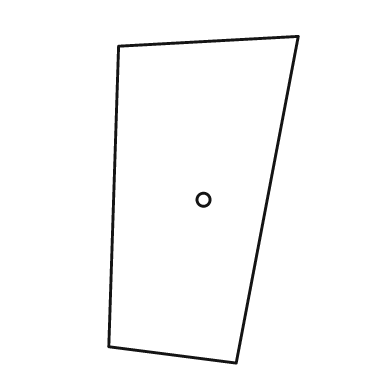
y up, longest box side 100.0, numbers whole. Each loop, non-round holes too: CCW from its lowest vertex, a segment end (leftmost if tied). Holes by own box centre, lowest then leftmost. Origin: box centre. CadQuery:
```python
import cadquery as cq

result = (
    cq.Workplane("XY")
    .moveTo(10.0, -50.0)
    .lineTo(29.0, 50.0)
    .lineTo(-26.0, 47.0)
    .lineTo(-29.0, -45.0)
    .close()
    .moveTo(0.0, 0.0)
    .circle(2.0)
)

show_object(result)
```